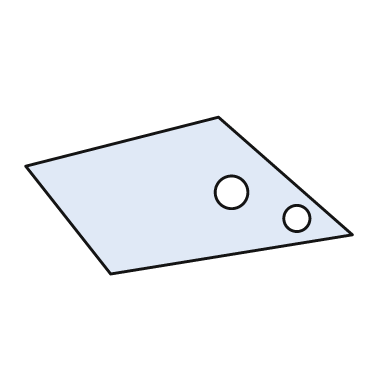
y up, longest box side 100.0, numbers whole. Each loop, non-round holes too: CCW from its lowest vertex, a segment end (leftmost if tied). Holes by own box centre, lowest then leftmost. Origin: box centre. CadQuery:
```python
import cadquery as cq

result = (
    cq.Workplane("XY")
    .moveTo(-24.0, -24.0)
    .lineTo(50.0, -12.0)
    .lineTo(9.0, 24.0)
    .lineTo(-50.0, 9.0)
    .close()
    .moveTo(33.0, -7.0)
    .circle(4.0)
    .moveTo(13.0, 1.0)
    .circle(5.0)
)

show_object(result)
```